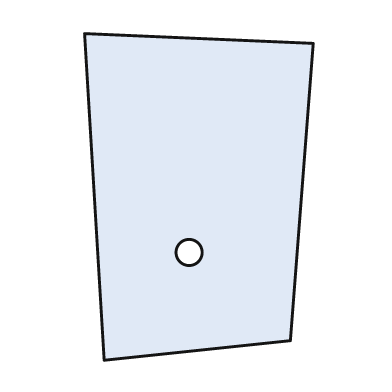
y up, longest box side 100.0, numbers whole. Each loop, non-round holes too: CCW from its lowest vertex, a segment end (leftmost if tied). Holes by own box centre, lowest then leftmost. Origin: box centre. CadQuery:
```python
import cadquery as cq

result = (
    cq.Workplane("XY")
    .moveTo(-29.0, -50.0)
    .lineTo(28.0, -44.0)
    .lineTo(35.0, 47.0)
    .lineTo(-35.0, 50.0)
    .close()
    .moveTo(-3.0, -17.0)
    .circle(4.0)
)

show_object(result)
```